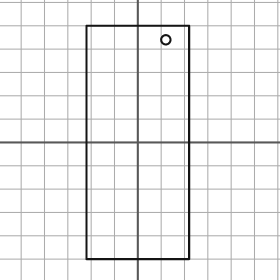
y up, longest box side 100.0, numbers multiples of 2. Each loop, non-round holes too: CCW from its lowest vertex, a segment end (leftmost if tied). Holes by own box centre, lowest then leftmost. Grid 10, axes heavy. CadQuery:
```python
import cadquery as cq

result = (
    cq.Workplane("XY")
    .moveTo(-22.0, -50.0)
    .lineTo(22.0, -50.0)
    .lineTo(22.0, 50.0)
    .lineTo(-22.0, 50.0)
    .close()
    .moveTo(12.0, 44.0)
    .circle(2.0)
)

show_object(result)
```